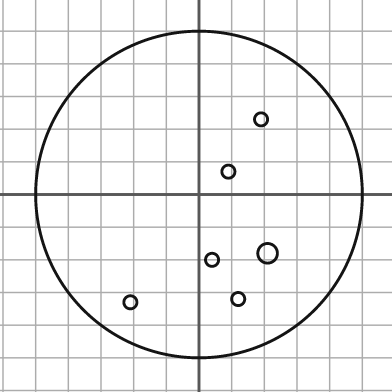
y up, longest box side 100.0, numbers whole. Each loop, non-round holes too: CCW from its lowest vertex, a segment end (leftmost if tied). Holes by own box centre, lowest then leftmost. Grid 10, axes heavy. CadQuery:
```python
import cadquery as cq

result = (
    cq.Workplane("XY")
    .moveTo(0.0, 0.0)
    .circle(50.0)
    .moveTo(-21.0, -33.0)
    .circle(2.0)
    .moveTo(12.0, -32.0)
    .circle(2.0)
    .moveTo(4.0, -20.0)
    .circle(2.0)
    .moveTo(21.0, -18.0)
    .circle(3.0)
    .moveTo(9.0, 7.0)
    .circle(2.0)
    .moveTo(19.0, 23.0)
    .circle(2.0)
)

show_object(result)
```